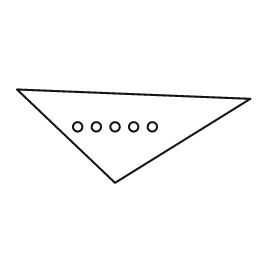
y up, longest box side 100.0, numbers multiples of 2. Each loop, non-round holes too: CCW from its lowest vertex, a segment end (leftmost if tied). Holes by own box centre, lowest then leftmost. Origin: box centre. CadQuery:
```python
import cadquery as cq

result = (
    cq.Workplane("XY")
    .moveTo(-8.0, -20.0)
    .lineTo(50.0, 16.0)
    .lineTo(-50.0, 20.0)
    .close()
    .moveTo(-24.0, 4.0)
    .circle(2.0)
    .moveTo(-16.0, 4.0)
    .circle(2.0)
    .moveTo(-8.0, 4.0)
    .circle(2.0)
    .moveTo(0.0, 4.0)
    .circle(2.0)
    .moveTo(8.0, 4.0)
    .circle(2.0)
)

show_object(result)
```